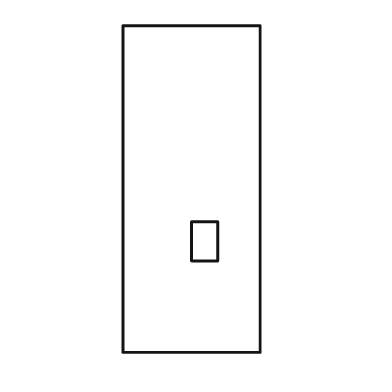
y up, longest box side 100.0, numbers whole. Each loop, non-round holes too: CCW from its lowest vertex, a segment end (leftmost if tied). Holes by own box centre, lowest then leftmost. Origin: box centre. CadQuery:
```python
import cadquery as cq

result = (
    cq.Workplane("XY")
    .moveTo(-21.0, -50.0)
    .lineTo(21.0, -50.0)
    .lineTo(21.0, 50.0)
    .lineTo(-21.0, 50.0)
    .close()
    .moveTo(0.0, -22.0)
    .lineTo(8.0, -22.0)
    .lineTo(8.0, -10.0)
    .lineTo(0.0, -10.0)
    .close()
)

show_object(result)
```